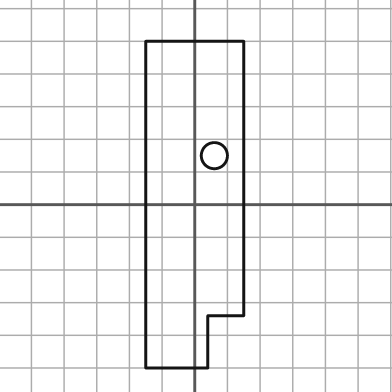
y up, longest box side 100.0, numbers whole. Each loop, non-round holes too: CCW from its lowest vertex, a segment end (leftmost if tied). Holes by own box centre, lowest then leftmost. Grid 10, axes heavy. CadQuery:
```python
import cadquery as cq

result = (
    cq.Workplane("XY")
    .moveTo(-15.0, -50.0)
    .lineTo(4.0, -50.0)
    .lineTo(4.0, -34.0)
    .lineTo(15.0, -34.0)
    .lineTo(15.0, 50.0)
    .lineTo(-15.0, 50.0)
    .close()
    .moveTo(6.0, 15.0)
    .circle(4.0)
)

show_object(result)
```